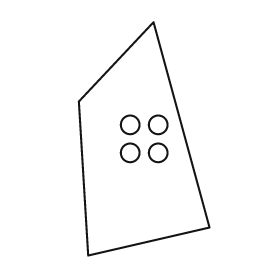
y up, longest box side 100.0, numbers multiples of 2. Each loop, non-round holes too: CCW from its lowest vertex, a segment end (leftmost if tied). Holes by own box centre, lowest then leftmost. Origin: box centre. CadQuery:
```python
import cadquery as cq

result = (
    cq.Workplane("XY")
    .moveTo(-24.0, -50.0)
    .lineTo(28.0, -38.0)
    .lineTo(4.0, 50.0)
    .lineTo(-28.0, 16.0)
    .close()
    .moveTo(-6.0, -6.0)
    .circle(4.0)
    .moveTo(6.0, -6.0)
    .circle(4.0)
    .moveTo(-6.0, 6.0)
    .circle(4.0)
    .moveTo(6.0, 6.0)
    .circle(4.0)
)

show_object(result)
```